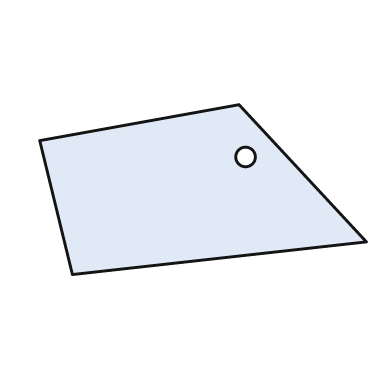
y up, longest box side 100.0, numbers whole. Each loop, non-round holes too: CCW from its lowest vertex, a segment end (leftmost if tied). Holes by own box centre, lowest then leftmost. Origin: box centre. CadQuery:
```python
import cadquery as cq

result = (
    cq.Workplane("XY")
    .moveTo(-40.0, -26.0)
    .lineTo(50.0, -16.0)
    .lineTo(11.0, 26.0)
    .lineTo(-50.0, 15.0)
    .close()
    .moveTo(13.0, 10.0)
    .circle(3.0)
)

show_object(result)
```